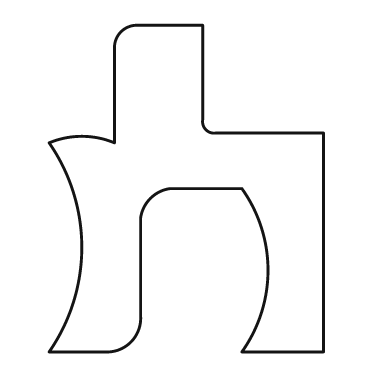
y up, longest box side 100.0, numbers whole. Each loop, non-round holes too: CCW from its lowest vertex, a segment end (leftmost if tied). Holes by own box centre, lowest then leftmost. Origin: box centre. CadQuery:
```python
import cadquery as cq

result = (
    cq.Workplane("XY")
    .moveTo(-42.0, -50.0)
    .lineTo(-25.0, -50.0)
    .threePointArc((-17.0, -47.0), (-14.0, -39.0))
    .lineTo(-14.0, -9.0)
    .threePointArc((-11.0, -3.0), (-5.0, 0.0))
    .lineTo(17.0, 0.0)
    .threePointArc((25.0, -25.0), (17.0, -50.0))
    .lineTo(42.0, -50.0)
    .lineTo(42.0, 17.0)
    .lineTo(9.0, 17.0)
    .threePointArc((6.0, 18.0), (5.0, 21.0))
    .lineTo(5.0, 50.0)
    .lineTo(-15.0, 50.0)
    .threePointArc((-20.0, 48.0), (-22.0, 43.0))
    .lineTo(-22.0, 14.0)
    .threePointArc((-32.0, 16.0), (-42.0, 14.0))
    .threePointArc((-32.0, -18.0), (-42.0, -50.0))
    .close()
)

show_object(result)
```